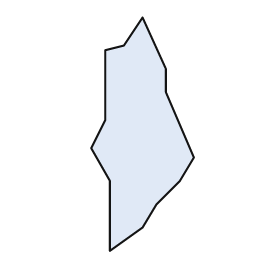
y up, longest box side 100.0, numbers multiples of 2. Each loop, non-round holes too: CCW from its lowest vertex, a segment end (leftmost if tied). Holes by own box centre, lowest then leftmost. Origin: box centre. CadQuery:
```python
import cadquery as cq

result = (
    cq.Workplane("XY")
    .moveTo(-14.0, -50.0)
    .lineTo(0.0, -40.0)
    .lineTo(6.0, -30.0)
    .lineTo(16.0, -20.0)
    .lineTo(22.0, -10.0)
    .lineTo(10.0, 18.0)
    .lineTo(10.0, 28.0)
    .lineTo(0.0, 50.0)
    .lineTo(-8.0, 38.0)
    .lineTo(-16.0, 36.0)
    .lineTo(-16.0, 6.0)
    .lineTo(-22.0, -6.0)
    .lineTo(-14.0, -20.0)
    .close()
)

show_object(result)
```